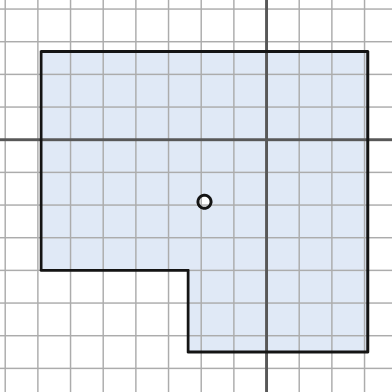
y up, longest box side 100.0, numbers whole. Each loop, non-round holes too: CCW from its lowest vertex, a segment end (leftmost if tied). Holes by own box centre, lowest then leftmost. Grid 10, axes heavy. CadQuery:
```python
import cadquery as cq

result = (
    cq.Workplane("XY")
    .moveTo(-24.0, -65.0)
    .lineTo(31.0, -65.0)
    .lineTo(31.0, 27.0)
    .lineTo(-69.0, 27.0)
    .lineTo(-69.0, -40.0)
    .lineTo(-24.0, -40.0)
    .close()
    .moveTo(-19.0, -19.0)
    .circle(2.0)
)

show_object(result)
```